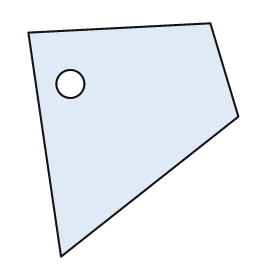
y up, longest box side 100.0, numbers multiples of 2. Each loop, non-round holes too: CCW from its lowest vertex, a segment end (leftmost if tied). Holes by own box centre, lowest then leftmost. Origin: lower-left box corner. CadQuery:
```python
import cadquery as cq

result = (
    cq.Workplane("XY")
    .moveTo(14.0, 0.0)
    .lineTo(90.0, 60.0)
    .lineTo(78.0, 100.0)
    .lineTo(0.0, 96.0)
    .close()
    .moveTo(18.0, 74.0)
    .circle(6.0)
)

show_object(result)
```